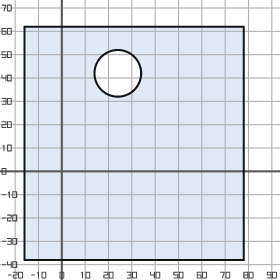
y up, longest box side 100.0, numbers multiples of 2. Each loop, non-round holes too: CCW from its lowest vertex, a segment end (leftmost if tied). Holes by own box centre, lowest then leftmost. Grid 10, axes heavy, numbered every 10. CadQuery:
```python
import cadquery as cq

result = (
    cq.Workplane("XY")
    .moveTo(-16.0, -38.0)
    .lineTo(78.0, -38.0)
    .lineTo(78.0, 62.0)
    .lineTo(-16.0, 62.0)
    .close()
    .moveTo(24.0, 42.0)
    .circle(10.0)
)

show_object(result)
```